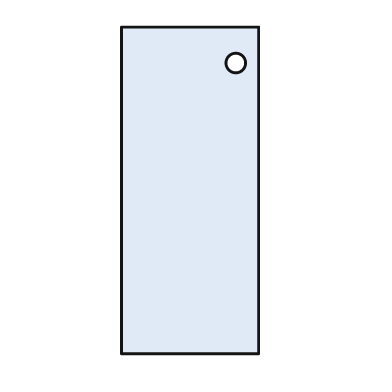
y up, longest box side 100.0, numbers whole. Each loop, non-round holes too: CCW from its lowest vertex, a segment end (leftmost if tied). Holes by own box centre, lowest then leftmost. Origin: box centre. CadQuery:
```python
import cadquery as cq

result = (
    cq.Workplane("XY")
    .moveTo(-21.0, -50.0)
    .lineTo(21.0, -50.0)
    .lineTo(21.0, 50.0)
    .lineTo(-21.0, 50.0)
    .close()
    .moveTo(14.0, 39.0)
    .circle(3.0)
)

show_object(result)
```